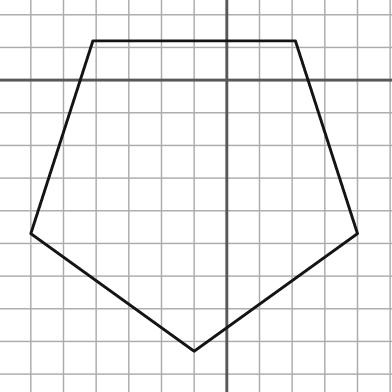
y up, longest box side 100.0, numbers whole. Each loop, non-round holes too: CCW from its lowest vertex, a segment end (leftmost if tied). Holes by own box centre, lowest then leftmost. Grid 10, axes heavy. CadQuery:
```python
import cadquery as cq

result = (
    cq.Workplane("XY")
    .moveTo(-10.0, -83.0)
    .lineTo(40.0, -47.0)
    .lineTo(21.0, 12.0)
    .lineTo(-41.0, 12.0)
    .lineTo(-60.0, -47.0)
    .close()
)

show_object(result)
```